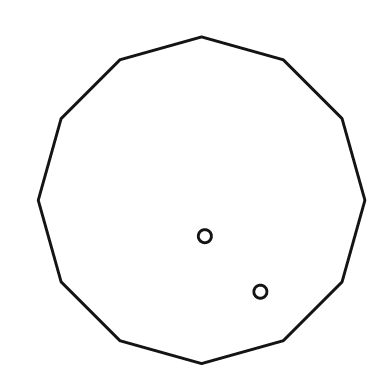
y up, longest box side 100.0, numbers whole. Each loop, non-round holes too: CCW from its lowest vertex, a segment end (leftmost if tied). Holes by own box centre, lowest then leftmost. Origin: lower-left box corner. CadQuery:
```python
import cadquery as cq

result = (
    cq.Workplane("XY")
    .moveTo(50.0, 0.0)
    .lineTo(75.0, 7.0)
    .lineTo(93.0, 25.0)
    .lineTo(100.0, 50.0)
    .lineTo(93.0, 75.0)
    .lineTo(75.0, 93.0)
    .lineTo(50.0, 100.0)
    .lineTo(25.0, 93.0)
    .lineTo(7.0, 75.0)
    .lineTo(0.0, 50.0)
    .lineTo(7.0, 25.0)
    .lineTo(25.0, 7.0)
    .close()
    .moveTo(68.0, 22.0)
    .circle(2.0)
    .moveTo(51.0, 39.0)
    .circle(2.0)
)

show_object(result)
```